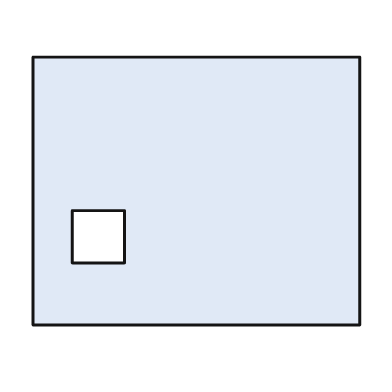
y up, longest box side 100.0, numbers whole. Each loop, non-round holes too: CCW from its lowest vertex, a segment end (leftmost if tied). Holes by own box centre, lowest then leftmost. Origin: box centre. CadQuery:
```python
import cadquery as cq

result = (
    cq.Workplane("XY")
    .moveTo(-50.0, -41.0)
    .lineTo(50.0, -41.0)
    .lineTo(50.0, 41.0)
    .lineTo(-50.0, 41.0)
    .close()
    .moveTo(-38.0, -22.0)
    .lineTo(-22.0, -22.0)
    .lineTo(-22.0, -6.0)
    .lineTo(-38.0, -6.0)
    .close()
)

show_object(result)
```